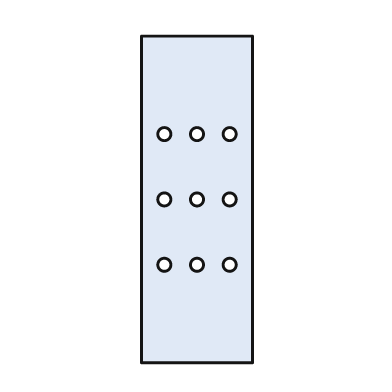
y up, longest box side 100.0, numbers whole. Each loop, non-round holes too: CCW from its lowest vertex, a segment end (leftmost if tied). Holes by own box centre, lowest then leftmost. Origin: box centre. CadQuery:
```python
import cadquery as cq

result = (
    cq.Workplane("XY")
    .moveTo(-17.0, -50.0)
    .lineTo(17.0, -50.0)
    .lineTo(17.0, 50.0)
    .lineTo(-17.0, 50.0)
    .close()
    .moveTo(-10.0, -20.0)
    .circle(2.0)
    .moveTo(0.0, -20.0)
    .circle(2.0)
    .moveTo(10.0, -20.0)
    .circle(2.0)
    .moveTo(-10.0, 0.0)
    .circle(2.0)
    .moveTo(0.0, 0.0)
    .circle(2.0)
    .moveTo(10.0, 0.0)
    .circle(2.0)
    .moveTo(-10.0, 20.0)
    .circle(2.0)
    .moveTo(0.0, 20.0)
    .circle(2.0)
    .moveTo(10.0, 20.0)
    .circle(2.0)
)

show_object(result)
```